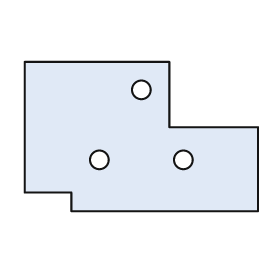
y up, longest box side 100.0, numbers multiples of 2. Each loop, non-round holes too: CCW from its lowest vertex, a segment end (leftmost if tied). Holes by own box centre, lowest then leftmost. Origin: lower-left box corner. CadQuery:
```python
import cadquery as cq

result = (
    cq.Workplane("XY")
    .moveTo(20.0, 0.0)
    .lineTo(100.0, 0.0)
    .lineTo(100.0, 36.0)
    .lineTo(62.0, 36.0)
    .lineTo(62.0, 64.0)
    .lineTo(0.0, 64.0)
    .lineTo(0.0, 8.0)
    .lineTo(20.0, 8.0)
    .close()
    .moveTo(32.0, 22.0)
    .circle(4.0)
    .moveTo(68.0, 22.0)
    .circle(4.0)
    .moveTo(50.0, 52.0)
    .circle(4.0)
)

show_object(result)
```